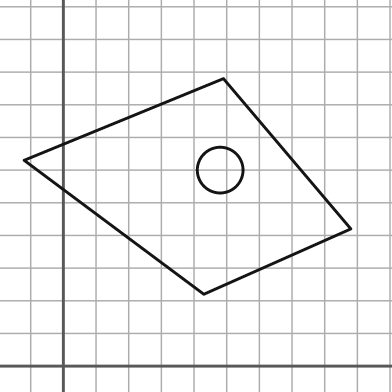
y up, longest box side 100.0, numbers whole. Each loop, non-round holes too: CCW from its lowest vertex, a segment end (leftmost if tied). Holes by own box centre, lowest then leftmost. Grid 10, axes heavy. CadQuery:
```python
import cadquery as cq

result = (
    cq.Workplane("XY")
    .moveTo(43.0, 22.0)
    .lineTo(88.0, 42.0)
    .lineTo(49.0, 88.0)
    .lineTo(-12.0, 63.0)
    .close()
    .moveTo(48.0, 60.0)
    .circle(7.0)
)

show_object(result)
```